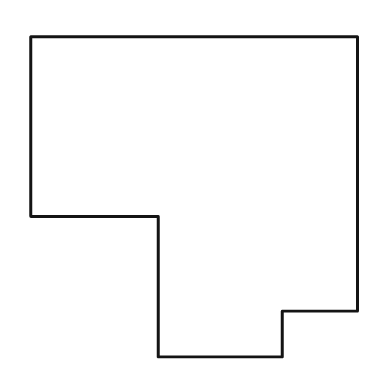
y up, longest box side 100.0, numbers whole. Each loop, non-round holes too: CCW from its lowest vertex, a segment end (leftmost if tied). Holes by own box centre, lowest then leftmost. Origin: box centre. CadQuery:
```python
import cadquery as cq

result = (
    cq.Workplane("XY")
    .moveTo(-11.0, -49.0)
    .lineTo(27.0, -49.0)
    .lineTo(27.0, -35.0)
    .lineTo(50.0, -35.0)
    .lineTo(50.0, 49.0)
    .lineTo(-50.0, 49.0)
    .lineTo(-50.0, -6.0)
    .lineTo(-11.0, -6.0)
    .close()
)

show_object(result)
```